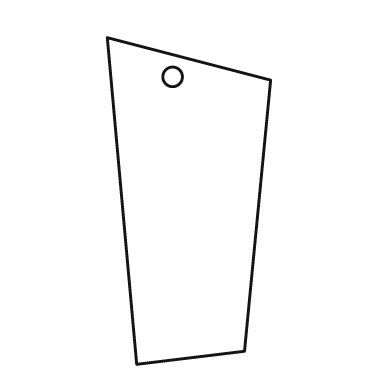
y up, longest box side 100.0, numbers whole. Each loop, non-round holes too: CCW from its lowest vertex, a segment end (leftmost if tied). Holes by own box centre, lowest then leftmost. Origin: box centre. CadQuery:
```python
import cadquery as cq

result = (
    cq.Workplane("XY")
    .moveTo(-16.0, -50.0)
    .lineTo(17.0, -46.0)
    .lineTo(25.0, 37.0)
    .lineTo(-25.0, 50.0)
    .close()
    .moveTo(-5.0, 38.0)
    .circle(3.0)
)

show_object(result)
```